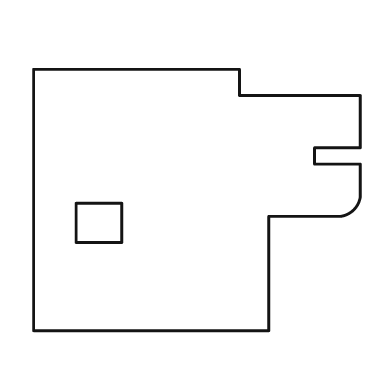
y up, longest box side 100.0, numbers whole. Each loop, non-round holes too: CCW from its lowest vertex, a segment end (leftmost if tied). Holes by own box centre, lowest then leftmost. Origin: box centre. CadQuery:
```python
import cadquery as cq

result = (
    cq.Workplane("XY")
    .moveTo(-50.0, -40.0)
    .lineTo(22.0, -40.0)
    .lineTo(22.0, -5.0)
    .lineTo(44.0, -5.0)
    .threePointArc((48.0, -3.0), (50.0, 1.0))
    .lineTo(50.0, 11.0)
    .lineTo(36.0, 11.0)
    .lineTo(36.0, 16.0)
    .lineTo(50.0, 16.0)
    .lineTo(50.0, 32.0)
    .lineTo(13.0, 32.0)
    .lineTo(13.0, 40.0)
    .lineTo(-50.0, 40.0)
    .close()
    .moveTo(-37.0, -13.0)
    .lineTo(-23.0, -13.0)
    .lineTo(-23.0, -1.0)
    .lineTo(-37.0, -1.0)
    .close()
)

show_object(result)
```